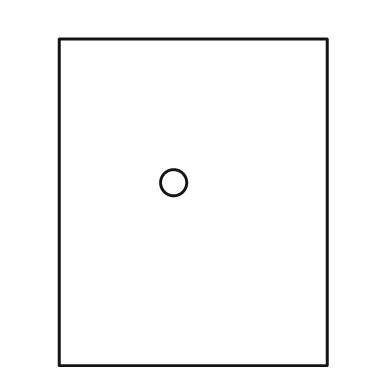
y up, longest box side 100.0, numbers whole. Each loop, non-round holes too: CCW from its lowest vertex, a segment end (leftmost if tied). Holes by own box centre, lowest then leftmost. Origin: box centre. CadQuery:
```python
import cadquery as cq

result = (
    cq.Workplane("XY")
    .moveTo(-41.0, -50.0)
    .lineTo(41.0, -50.0)
    .lineTo(41.0, 50.0)
    .lineTo(-41.0, 50.0)
    .close()
    .moveTo(-6.0, 6.0)
    .circle(4.0)
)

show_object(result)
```